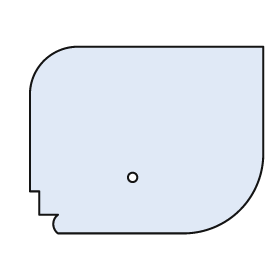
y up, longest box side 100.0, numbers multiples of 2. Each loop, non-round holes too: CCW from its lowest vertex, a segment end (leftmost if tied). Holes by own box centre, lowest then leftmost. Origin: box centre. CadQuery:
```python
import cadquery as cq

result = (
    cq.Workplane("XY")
    .moveTo(-38.0, -40.0)
    .lineTo(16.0, -40.0)
    .threePointArc((40.0, -30.0), (50.0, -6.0))
    .lineTo(50.0, 40.0)
    .lineTo(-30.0, 40.0)
    .threePointArc((-44.0, 34.0), (-50.0, 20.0))
    .lineTo(-50.0, -22.0)
    .lineTo(-46.0, -22.0)
    .lineTo(-46.0, -32.0)
    .lineTo(-38.0, -32.0)
    .threePointArc((-40.0, -36.0), (-38.0, -40.0))
    .close()
    .moveTo(-6.0, -16.0)
    .circle(2.0)
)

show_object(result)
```